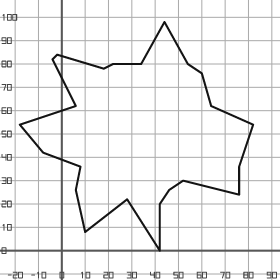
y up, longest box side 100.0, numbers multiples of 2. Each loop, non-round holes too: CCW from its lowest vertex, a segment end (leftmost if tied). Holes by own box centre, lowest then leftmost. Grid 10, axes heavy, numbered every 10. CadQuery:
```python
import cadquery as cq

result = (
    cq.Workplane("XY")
    .moveTo(42.0, 0.0)
    .lineTo(42.0, 20.0)
    .lineTo(46.0, 26.0)
    .lineTo(52.0, 30.0)
    .lineTo(76.0, 24.0)
    .lineTo(76.0, 36.0)
    .lineTo(82.0, 54.0)
    .lineTo(64.0, 62.0)
    .lineTo(60.0, 76.0)
    .lineTo(54.0, 80.0)
    .lineTo(44.0, 98.0)
    .lineTo(34.0, 80.0)
    .lineTo(22.0, 80.0)
    .lineTo(18.0, 78.0)
    .lineTo(-2.0, 84.0)
    .lineTo(-4.0, 82.0)
    .lineTo(6.0, 62.0)
    .lineTo(-18.0, 54.0)
    .lineTo(-8.0, 42.0)
    .lineTo(8.0, 36.0)
    .lineTo(6.0, 26.0)
    .lineTo(10.0, 8.0)
    .lineTo(28.0, 22.0)
    .close()
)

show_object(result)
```